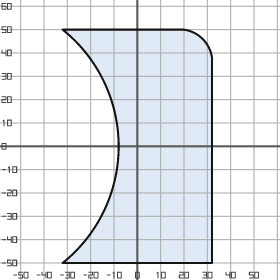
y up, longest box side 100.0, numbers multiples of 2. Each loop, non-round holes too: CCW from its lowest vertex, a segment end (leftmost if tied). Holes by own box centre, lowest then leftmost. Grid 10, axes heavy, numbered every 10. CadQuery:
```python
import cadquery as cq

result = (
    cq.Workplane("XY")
    .moveTo(-32.0, -50.0)
    .lineTo(32.0, -50.0)
    .lineTo(32.0, 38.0)
    .threePointArc((28.0, 46.0), (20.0, 50.0))
    .lineTo(-32.0, 50.0)
    .threePointArc((-8.0, 0.0), (-32.0, -50.0))
    .close()
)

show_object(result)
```